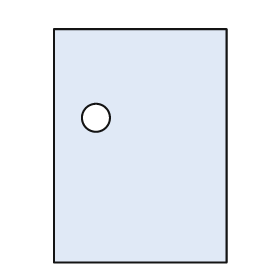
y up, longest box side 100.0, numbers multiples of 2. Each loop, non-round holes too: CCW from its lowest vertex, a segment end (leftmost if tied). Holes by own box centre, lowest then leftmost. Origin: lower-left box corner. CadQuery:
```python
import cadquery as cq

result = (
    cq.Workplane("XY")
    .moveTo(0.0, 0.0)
    .lineTo(74.0, 0.0)
    .lineTo(74.0, 100.0)
    .lineTo(0.0, 100.0)
    .close()
    .moveTo(18.0, 62.0)
    .circle(6.0)
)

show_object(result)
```